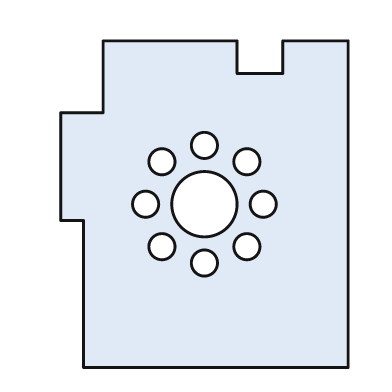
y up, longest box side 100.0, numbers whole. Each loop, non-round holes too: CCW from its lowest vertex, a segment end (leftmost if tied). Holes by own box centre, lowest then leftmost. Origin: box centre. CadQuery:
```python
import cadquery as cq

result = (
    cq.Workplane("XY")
    .moveTo(-37.0, -50.0)
    .lineTo(44.0, -50.0)
    .lineTo(44.0, 50.0)
    .lineTo(24.0, 50.0)
    .lineTo(24.0, 40.0)
    .lineTo(10.0, 40.0)
    .lineTo(10.0, 50.0)
    .lineTo(-31.0, 50.0)
    .lineTo(-31.0, 28.0)
    .lineTo(-44.0, 28.0)
    .lineTo(-44.0, -5.0)
    .lineTo(-37.0, -5.0)
    .close()
    .moveTo(0.0, -18.0)
    .circle(4.0)
    .moveTo(-13.0, -13.0)
    .circle(4.0)
    .moveTo(13.0, -13.0)
    .circle(4.0)
    .moveTo(-18.0, 0.0)
    .circle(4.0)
    .moveTo(0.0, 0.0)
    .circle(10.0)
    .moveTo(18.0, 0.0)
    .circle(4.0)
    .moveTo(-13.0, 13.0)
    .circle(4.0)
    .moveTo(13.0, 13.0)
    .circle(4.0)
    .moveTo(0.0, 18.0)
    .circle(4.0)
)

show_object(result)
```